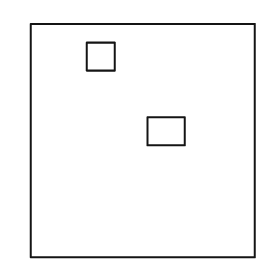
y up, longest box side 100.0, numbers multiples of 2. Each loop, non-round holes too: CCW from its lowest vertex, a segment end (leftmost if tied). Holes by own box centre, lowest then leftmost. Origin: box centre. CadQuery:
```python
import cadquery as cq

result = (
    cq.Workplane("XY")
    .moveTo(-48.0, -50.0)
    .lineTo(48.0, -50.0)
    .lineTo(48.0, 50.0)
    .lineTo(-48.0, 50.0)
    .close()
    .moveTo(2.0, -2.0)
    .lineTo(18.0, -2.0)
    .lineTo(18.0, 10.0)
    .lineTo(2.0, 10.0)
    .close()
    .moveTo(-24.0, 30.0)
    .lineTo(-12.0, 30.0)
    .lineTo(-12.0, 42.0)
    .lineTo(-24.0, 42.0)
    .close()
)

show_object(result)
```